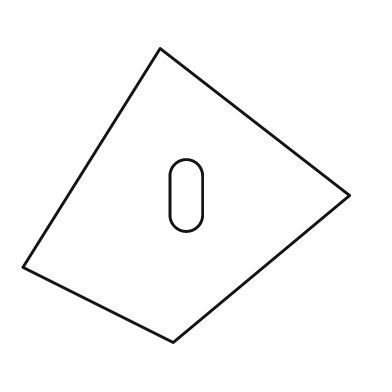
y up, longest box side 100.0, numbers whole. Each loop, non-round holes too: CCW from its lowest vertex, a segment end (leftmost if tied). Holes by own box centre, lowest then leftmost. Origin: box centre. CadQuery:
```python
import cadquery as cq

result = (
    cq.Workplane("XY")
    .moveTo(-4.0, -45.0)
    .lineTo(50.0, 0.0)
    .lineTo(-8.0, 45.0)
    .lineTo(-50.0, -22.0)
    .close()
    .moveTo(-5.0, -6.0)
    .threePointArc((0.0, -11.0), (5.0, -6.0))
    .lineTo(5.0, 6.0)
    .threePointArc((0.0, 11.0), (-5.0, 6.0))
    .close()
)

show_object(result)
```